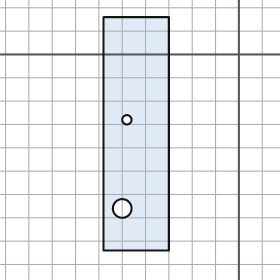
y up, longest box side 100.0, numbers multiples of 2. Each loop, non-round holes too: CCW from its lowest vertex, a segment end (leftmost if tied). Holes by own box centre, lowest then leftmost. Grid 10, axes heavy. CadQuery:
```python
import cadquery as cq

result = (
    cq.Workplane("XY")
    .moveTo(-58.0, -84.0)
    .lineTo(-30.0, -84.0)
    .lineTo(-30.0, 16.0)
    .lineTo(-58.0, 16.0)
    .close()
    .moveTo(-50.0, -66.0)
    .circle(4.0)
    .moveTo(-48.0, -28.0)
    .circle(2.0)
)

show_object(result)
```